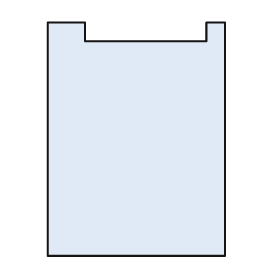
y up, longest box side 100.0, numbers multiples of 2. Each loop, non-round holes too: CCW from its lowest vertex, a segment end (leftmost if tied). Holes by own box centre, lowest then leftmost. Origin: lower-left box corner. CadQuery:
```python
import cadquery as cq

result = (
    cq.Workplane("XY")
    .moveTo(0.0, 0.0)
    .lineTo(76.0, 0.0)
    .lineTo(76.0, 100.0)
    .lineTo(68.0, 100.0)
    .lineTo(68.0, 92.0)
    .lineTo(16.0, 92.0)
    .lineTo(16.0, 100.0)
    .lineTo(0.0, 100.0)
    .close()
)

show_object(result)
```